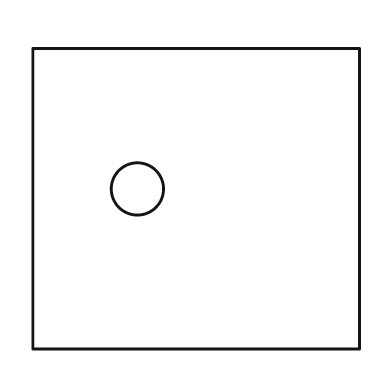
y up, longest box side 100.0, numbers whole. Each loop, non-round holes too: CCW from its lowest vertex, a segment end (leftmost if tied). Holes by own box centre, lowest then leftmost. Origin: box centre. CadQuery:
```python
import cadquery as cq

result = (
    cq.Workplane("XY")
    .moveTo(-50.0, -46.0)
    .lineTo(50.0, -46.0)
    .lineTo(50.0, 46.0)
    .lineTo(-50.0, 46.0)
    .close()
    .moveTo(-18.0, 3.0)
    .circle(8.0)
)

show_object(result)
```